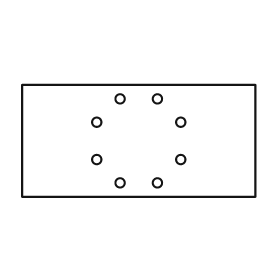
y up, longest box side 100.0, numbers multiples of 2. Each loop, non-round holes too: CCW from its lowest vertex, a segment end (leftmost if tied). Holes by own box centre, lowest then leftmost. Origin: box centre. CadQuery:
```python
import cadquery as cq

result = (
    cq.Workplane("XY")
    .moveTo(-50.0, -24.0)
    .lineTo(50.0, -24.0)
    .lineTo(50.0, 24.0)
    .lineTo(-50.0, 24.0)
    .close()
    .moveTo(-8.0, -18.0)
    .circle(2.0)
    .moveTo(8.0, -18.0)
    .circle(2.0)
    .moveTo(-18.0, -8.0)
    .circle(2.0)
    .moveTo(18.0, -8.0)
    .circle(2.0)
    .moveTo(-18.0, 8.0)
    .circle(2.0)
    .moveTo(18.0, 8.0)
    .circle(2.0)
    .moveTo(-8.0, 18.0)
    .circle(2.0)
    .moveTo(8.0, 18.0)
    .circle(2.0)
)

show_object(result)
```